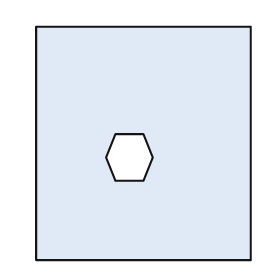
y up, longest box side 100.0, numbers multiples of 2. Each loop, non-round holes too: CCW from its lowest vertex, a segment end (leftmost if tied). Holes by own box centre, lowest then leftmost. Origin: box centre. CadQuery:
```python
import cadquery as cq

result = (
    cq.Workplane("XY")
    .moveTo(-46.0, -50.0)
    .lineTo(46.0, -50.0)
    .lineTo(46.0, 50.0)
    .lineTo(-46.0, 50.0)
    .close()
    .moveTo(-12.0, -16.0)
    .lineTo(0.0, -16.0)
    .lineTo(4.0, -6.0)
    .lineTo(0.0, 4.0)
    .lineTo(-12.0, 4.0)
    .lineTo(-16.0, -6.0)
    .close()
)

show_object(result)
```